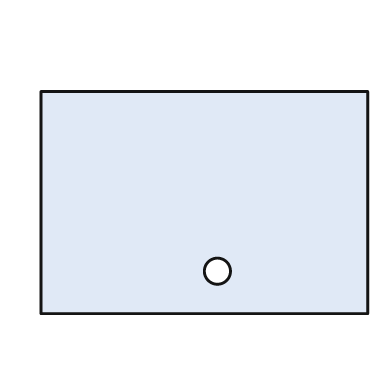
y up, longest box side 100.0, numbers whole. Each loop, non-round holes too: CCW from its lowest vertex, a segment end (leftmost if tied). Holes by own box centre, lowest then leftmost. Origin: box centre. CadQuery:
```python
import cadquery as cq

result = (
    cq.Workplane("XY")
    .moveTo(-50.0, -34.0)
    .lineTo(50.0, -34.0)
    .lineTo(50.0, 34.0)
    .lineTo(-50.0, 34.0)
    .close()
    .moveTo(4.0, -21.0)
    .circle(4.0)
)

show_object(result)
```